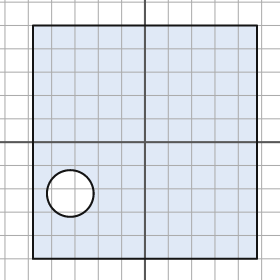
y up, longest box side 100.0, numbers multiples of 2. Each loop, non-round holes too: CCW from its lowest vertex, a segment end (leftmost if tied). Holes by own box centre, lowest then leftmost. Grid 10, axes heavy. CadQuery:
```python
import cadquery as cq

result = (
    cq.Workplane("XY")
    .moveTo(-48.0, -50.0)
    .lineTo(48.0, -50.0)
    .lineTo(48.0, 50.0)
    .lineTo(-48.0, 50.0)
    .close()
    .moveTo(-32.0, -22.0)
    .circle(10.0)
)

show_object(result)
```